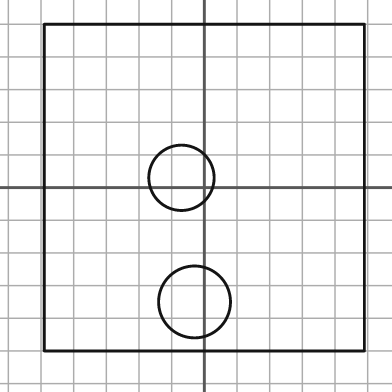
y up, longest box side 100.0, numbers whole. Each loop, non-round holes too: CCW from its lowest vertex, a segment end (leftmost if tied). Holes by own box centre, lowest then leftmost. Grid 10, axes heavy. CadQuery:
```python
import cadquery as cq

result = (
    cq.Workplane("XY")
    .moveTo(-49.0, -50.0)
    .lineTo(49.0, -50.0)
    .lineTo(49.0, 50.0)
    .lineTo(-49.0, 50.0)
    .close()
    .moveTo(-3.0, -35.0)
    .circle(11.0)
    .moveTo(-7.0, 3.0)
    .circle(10.0)
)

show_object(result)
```